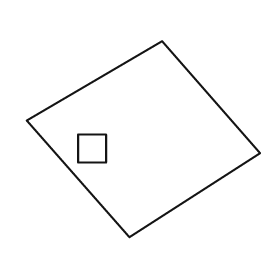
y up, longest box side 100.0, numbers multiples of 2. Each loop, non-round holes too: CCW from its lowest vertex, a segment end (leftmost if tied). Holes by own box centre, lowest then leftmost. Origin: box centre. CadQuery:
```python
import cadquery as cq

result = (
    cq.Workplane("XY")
    .moveTo(-6.0, -42.0)
    .lineTo(50.0, -6.0)
    .lineTo(8.0, 42.0)
    .lineTo(-50.0, 8.0)
    .close()
    .moveTo(-28.0, -10.0)
    .lineTo(-16.0, -10.0)
    .lineTo(-16.0, 2.0)
    .lineTo(-28.0, 2.0)
    .close()
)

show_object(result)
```